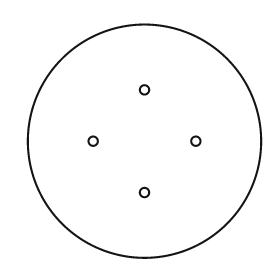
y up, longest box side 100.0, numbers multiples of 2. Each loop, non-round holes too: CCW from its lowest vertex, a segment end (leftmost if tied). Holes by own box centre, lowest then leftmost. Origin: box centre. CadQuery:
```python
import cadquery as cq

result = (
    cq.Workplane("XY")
    .moveTo(0.0, 0.0)
    .circle(50.0)
    .moveTo(0.0, -22.0)
    .circle(2.0)
    .moveTo(-22.0, 0.0)
    .circle(2.0)
    .moveTo(22.0, 0.0)
    .circle(2.0)
    .moveTo(0.0, 22.0)
    .circle(2.0)
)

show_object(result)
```